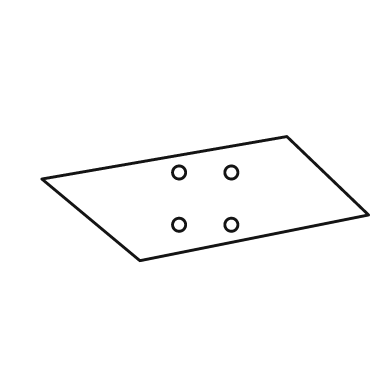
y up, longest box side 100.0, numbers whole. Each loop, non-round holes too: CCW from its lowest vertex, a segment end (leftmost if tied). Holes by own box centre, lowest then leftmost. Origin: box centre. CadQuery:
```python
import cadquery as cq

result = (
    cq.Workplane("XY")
    .moveTo(-20.0, -19.0)
    .lineTo(50.0, -5.0)
    .lineTo(25.0, 19.0)
    .lineTo(-50.0, 6.0)
    .close()
    .moveTo(-8.0, -8.0)
    .circle(2.0)
    .moveTo(8.0, -8.0)
    .circle(2.0)
    .moveTo(-8.0, 8.0)
    .circle(2.0)
    .moveTo(8.0, 8.0)
    .circle(2.0)
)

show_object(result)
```